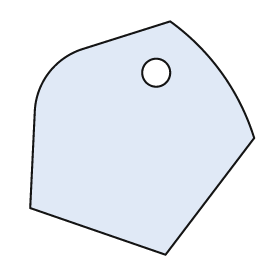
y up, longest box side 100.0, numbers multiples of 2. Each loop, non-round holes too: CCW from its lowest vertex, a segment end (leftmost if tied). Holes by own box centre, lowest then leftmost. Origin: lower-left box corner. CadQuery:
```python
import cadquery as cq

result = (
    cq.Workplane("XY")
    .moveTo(58.0, 0.0)
    .lineTo(96.0, 50.0)
    .threePointArc((82.0, 78.0), (60.0, 100.0))
    .lineTo(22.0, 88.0)
    .threePointArc((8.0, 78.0), (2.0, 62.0))
    .lineTo(0.0, 20.0)
    .close()
    .moveTo(54.0, 78.0)
    .circle(6.0)
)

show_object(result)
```